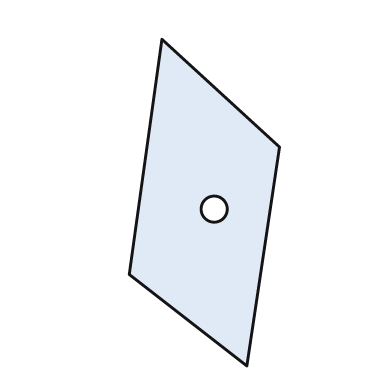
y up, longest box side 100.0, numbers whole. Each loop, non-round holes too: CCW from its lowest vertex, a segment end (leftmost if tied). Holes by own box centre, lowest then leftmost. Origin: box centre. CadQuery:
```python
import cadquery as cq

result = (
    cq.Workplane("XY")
    .moveTo(13.0, -50.0)
    .lineTo(23.0, 17.0)
    .lineTo(-13.0, 50.0)
    .lineTo(-23.0, -22.0)
    .close()
    .moveTo(3.0, -2.0)
    .circle(4.0)
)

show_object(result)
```